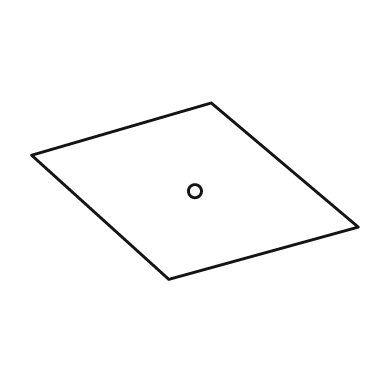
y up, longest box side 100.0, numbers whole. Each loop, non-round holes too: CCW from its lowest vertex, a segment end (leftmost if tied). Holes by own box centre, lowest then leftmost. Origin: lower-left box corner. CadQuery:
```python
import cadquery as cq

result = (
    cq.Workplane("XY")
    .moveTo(42.0, 0.0)
    .lineTo(100.0, 16.0)
    .lineTo(55.0, 54.0)
    .lineTo(0.0, 38.0)
    .close()
    .moveTo(50.0, 27.0)
    .circle(2.0)
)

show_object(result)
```